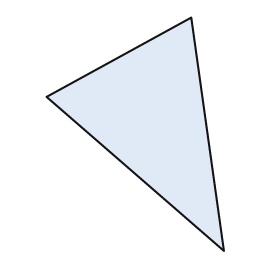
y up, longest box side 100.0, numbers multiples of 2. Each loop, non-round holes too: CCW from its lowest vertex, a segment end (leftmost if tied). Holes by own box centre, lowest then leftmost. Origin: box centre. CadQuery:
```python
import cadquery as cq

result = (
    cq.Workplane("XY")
    .moveTo(38.0, -50.0)
    .lineTo(24.0, 50.0)
    .lineTo(-38.0, 16.0)
    .close()
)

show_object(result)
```